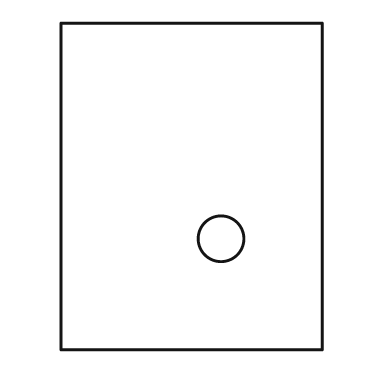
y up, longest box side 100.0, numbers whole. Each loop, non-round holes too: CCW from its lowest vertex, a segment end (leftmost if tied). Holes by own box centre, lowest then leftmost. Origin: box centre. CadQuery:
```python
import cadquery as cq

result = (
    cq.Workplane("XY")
    .moveTo(-40.0, -50.0)
    .lineTo(40.0, -50.0)
    .lineTo(40.0, 50.0)
    .lineTo(-40.0, 50.0)
    .close()
    .moveTo(9.0, -16.0)
    .circle(7.0)
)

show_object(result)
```